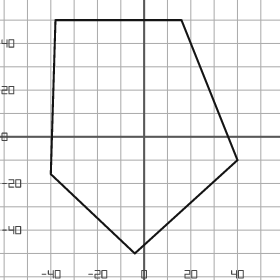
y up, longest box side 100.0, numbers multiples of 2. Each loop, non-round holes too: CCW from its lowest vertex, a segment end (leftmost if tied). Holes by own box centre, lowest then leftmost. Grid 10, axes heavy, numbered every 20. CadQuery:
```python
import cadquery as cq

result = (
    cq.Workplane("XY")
    .moveTo(-4.0, -50.0)
    .lineTo(40.0, -10.0)
    .lineTo(16.0, 50.0)
    .lineTo(-38.0, 50.0)
    .lineTo(-40.0, -16.0)
    .close()
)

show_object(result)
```